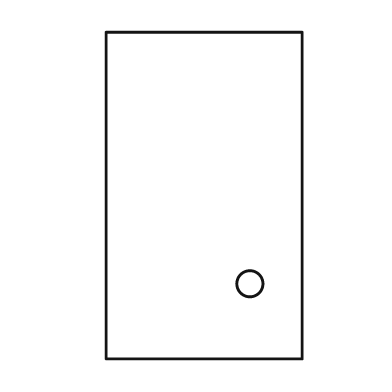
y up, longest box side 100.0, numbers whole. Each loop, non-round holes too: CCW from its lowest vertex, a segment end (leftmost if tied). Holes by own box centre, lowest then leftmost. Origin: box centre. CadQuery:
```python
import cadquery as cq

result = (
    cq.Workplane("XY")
    .moveTo(-30.0, -50.0)
    .lineTo(30.0, -50.0)
    .lineTo(30.0, 50.0)
    .lineTo(-30.0, 50.0)
    .close()
    .moveTo(14.0, -27.0)
    .circle(4.0)
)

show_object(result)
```